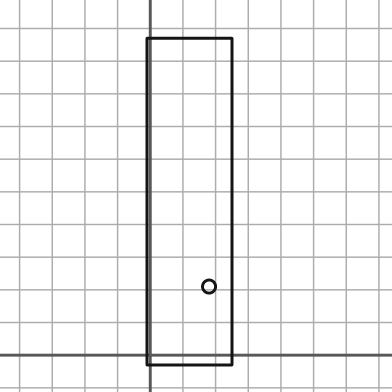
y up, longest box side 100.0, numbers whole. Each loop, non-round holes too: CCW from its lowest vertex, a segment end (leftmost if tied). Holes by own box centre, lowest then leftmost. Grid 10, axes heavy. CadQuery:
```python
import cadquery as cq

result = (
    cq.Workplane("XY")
    .moveTo(-1.0, -3.0)
    .lineTo(25.0, -3.0)
    .lineTo(25.0, 97.0)
    .lineTo(-1.0, 97.0)
    .close()
    .moveTo(18.0, 21.0)
    .circle(2.0)
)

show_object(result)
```